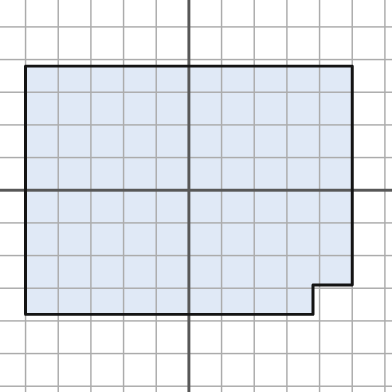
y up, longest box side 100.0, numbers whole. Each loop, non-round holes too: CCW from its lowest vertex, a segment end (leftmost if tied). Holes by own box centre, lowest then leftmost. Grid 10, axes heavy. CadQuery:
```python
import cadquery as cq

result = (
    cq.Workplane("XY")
    .moveTo(-50.0, -38.0)
    .lineTo(38.0, -38.0)
    .lineTo(38.0, -29.0)
    .lineTo(50.0, -29.0)
    .lineTo(50.0, 38.0)
    .lineTo(-50.0, 38.0)
    .close()
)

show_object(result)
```